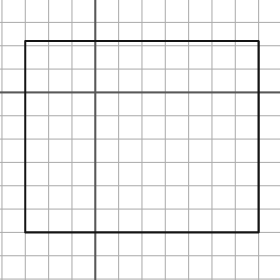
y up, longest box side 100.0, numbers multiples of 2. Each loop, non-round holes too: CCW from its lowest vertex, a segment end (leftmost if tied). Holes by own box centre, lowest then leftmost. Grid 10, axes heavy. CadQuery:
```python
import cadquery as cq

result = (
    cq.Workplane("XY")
    .moveTo(-30.0, -60.0)
    .lineTo(70.0, -60.0)
    .lineTo(70.0, 22.0)
    .lineTo(-30.0, 22.0)
    .close()
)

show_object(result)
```